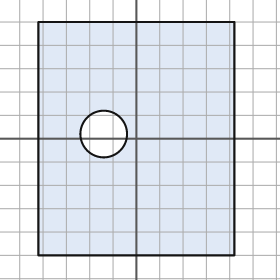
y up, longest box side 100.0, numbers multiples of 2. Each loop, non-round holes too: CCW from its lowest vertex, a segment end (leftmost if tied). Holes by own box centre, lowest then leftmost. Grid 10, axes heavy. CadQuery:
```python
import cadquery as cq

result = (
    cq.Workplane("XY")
    .moveTo(-42.0, -50.0)
    .lineTo(42.0, -50.0)
    .lineTo(42.0, 50.0)
    .lineTo(-42.0, 50.0)
    .close()
    .moveTo(-14.0, 2.0)
    .circle(10.0)
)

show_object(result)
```